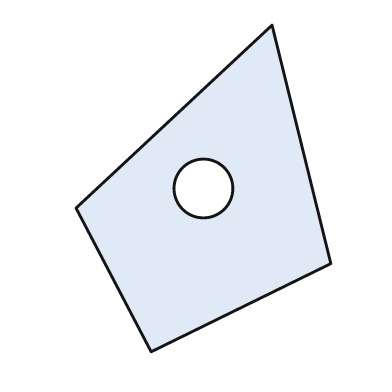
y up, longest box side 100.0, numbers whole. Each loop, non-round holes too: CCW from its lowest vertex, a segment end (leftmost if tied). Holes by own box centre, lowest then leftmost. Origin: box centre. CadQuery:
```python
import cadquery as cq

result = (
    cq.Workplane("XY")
    .moveTo(-16.0, -50.0)
    .lineTo(39.0, -23.0)
    .lineTo(21.0, 50.0)
    .lineTo(-39.0, -6.0)
    .close()
    .moveTo(0.0, 0.0)
    .circle(9.0)
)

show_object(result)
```